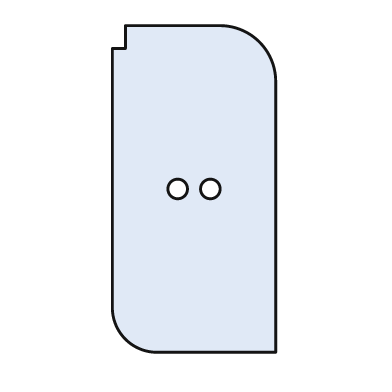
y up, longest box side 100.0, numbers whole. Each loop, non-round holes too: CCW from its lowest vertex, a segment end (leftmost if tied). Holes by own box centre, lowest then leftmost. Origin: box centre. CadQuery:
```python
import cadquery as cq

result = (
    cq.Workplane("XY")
    .moveTo(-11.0, -50.0)
    .lineTo(25.0, -50.0)
    .lineTo(25.0, 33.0)
    .threePointArc((20.0, 45.0), (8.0, 50.0))
    .lineTo(-21.0, 50.0)
    .lineTo(-21.0, 43.0)
    .lineTo(-25.0, 43.0)
    .lineTo(-25.0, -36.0)
    .threePointArc((-21.0, -46.0), (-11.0, -50.0))
    .close()
    .moveTo(-5.0, 0.0)
    .circle(3.0)
    .moveTo(5.0, 0.0)
    .circle(3.0)
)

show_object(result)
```